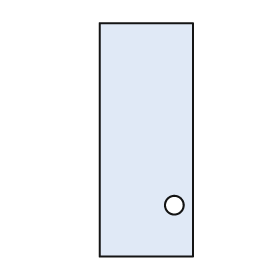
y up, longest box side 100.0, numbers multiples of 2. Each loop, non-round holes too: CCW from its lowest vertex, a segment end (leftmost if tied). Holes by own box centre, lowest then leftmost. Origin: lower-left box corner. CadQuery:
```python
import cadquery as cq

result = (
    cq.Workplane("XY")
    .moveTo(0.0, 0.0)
    .lineTo(40.0, 0.0)
    .lineTo(40.0, 100.0)
    .lineTo(0.0, 100.0)
    .close()
    .moveTo(32.0, 22.0)
    .circle(4.0)
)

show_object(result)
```